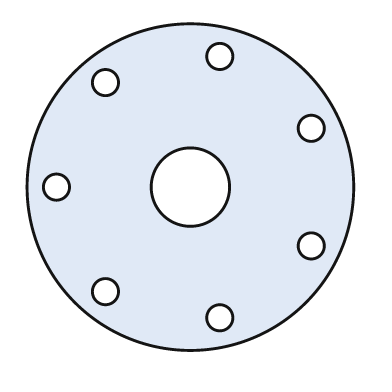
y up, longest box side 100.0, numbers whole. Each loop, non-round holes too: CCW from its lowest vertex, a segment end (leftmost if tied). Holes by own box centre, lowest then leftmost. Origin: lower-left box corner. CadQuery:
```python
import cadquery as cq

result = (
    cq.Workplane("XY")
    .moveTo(50.0, 50.0)
    .circle(50.0)
    .moveTo(59.0, 10.0)
    .circle(4.0)
    .moveTo(24.0, 18.0)
    .circle(4.0)
    .moveTo(87.0, 32.0)
    .circle(4.0)
    .moveTo(9.0, 50.0)
    .circle(4.0)
    .moveTo(50.0, 50.0)
    .circle(12.0)
    .moveTo(87.0, 68.0)
    .circle(4.0)
    .moveTo(24.0, 82.0)
    .circle(4.0)
    .moveTo(59.0, 90.0)
    .circle(4.0)
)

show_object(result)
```